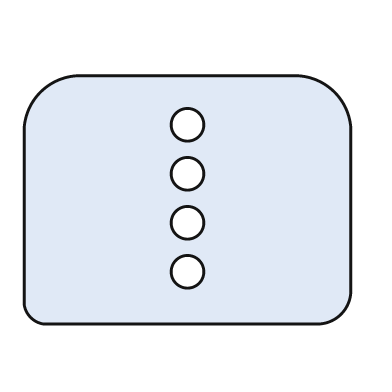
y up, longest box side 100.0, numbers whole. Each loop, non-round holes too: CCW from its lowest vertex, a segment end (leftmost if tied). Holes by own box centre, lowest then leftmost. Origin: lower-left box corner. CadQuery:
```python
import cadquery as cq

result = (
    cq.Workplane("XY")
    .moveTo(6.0, 0.0)
    .lineTo(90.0, 0.0)
    .threePointArc((97.0, 3.0), (100.0, 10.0))
    .lineTo(100.0, 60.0)
    .threePointArc((95.0, 71.0), (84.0, 76.0))
    .lineTo(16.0, 76.0)
    .threePointArc((5.0, 71.0), (0.0, 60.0))
    .lineTo(0.0, 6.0)
    .threePointArc((2.0, 2.0), (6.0, 0.0))
    .close()
    .moveTo(50.0, 16.0)
    .circle(5.0)
    .moveTo(50.0, 31.0)
    .circle(5.0)
    .moveTo(50.0, 46.0)
    .circle(5.0)
    .moveTo(50.0, 61.0)
    .circle(5.0)
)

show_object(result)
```